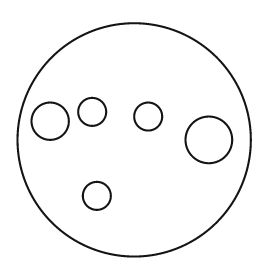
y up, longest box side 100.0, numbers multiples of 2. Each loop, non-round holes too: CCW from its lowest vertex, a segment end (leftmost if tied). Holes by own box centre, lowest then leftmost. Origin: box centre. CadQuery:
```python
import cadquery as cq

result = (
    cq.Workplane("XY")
    .moveTo(0.0, 0.0)
    .circle(50.0)
    .moveTo(-16.0, -24.0)
    .circle(6.0)
    .moveTo(32.0, 0.0)
    .circle(10.0)
    .moveTo(-36.0, 8.0)
    .circle(8.0)
    .moveTo(6.0, 10.0)
    .circle(6.0)
    .moveTo(-18.0, 12.0)
    .circle(6.0)
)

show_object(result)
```